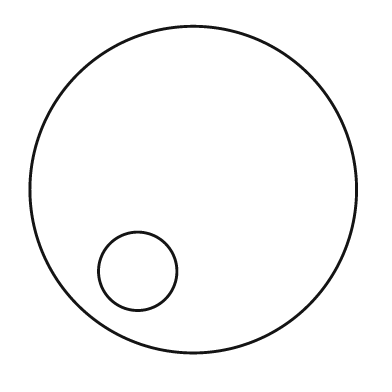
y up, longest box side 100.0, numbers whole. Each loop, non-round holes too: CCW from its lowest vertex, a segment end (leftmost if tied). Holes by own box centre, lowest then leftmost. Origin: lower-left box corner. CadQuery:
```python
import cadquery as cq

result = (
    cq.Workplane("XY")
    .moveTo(50.0, 50.0)
    .circle(50.0)
    .moveTo(33.0, 25.0)
    .circle(12.0)
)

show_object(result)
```